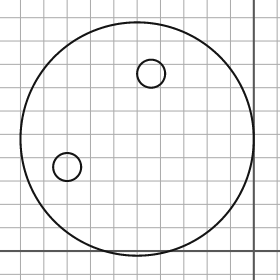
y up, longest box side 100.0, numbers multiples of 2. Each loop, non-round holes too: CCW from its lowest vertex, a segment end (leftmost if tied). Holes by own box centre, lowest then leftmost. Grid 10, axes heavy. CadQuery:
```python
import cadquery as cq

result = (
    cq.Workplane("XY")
    .moveTo(-50.0, 48.0)
    .circle(50.0)
    .moveTo(-80.0, 36.0)
    .circle(6.0)
    .moveTo(-44.0, 76.0)
    .circle(6.0)
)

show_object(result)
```